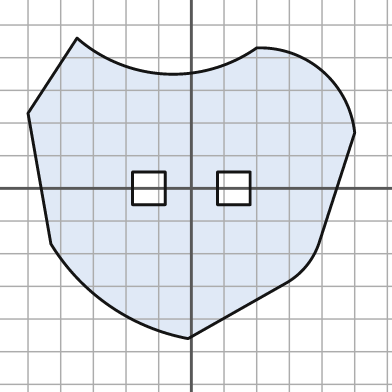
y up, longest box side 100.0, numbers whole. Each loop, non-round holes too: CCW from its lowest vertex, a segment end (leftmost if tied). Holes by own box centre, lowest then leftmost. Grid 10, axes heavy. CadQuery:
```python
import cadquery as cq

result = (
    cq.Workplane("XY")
    .moveTo(-1.0, -46.0)
    .lineTo(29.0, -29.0)
    .threePointArc((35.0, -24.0), (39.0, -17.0))
    .lineTo(50.0, 17.0)
    .threePointArc((40.0, 36.0), (20.0, 43.0))
    .threePointArc((-8.0, 35.0), (-35.0, 46.0))
    .lineTo(-50.0, 23.0)
    .lineTo(-43.0, -17.0)
    .threePointArc((-25.0, -36.0), (-1.0, -46.0))
    .close()
    .moveTo(-18.0, -5.0)
    .lineTo(-8.0, -5.0)
    .lineTo(-8.0, 5.0)
    .lineTo(-18.0, 5.0)
    .close()
    .moveTo(8.0, -5.0)
    .lineTo(18.0, -5.0)
    .lineTo(18.0, 5.0)
    .lineTo(8.0, 5.0)
    .close()
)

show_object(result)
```